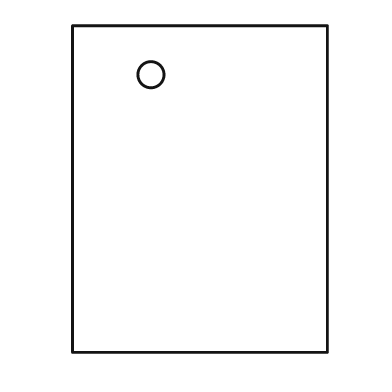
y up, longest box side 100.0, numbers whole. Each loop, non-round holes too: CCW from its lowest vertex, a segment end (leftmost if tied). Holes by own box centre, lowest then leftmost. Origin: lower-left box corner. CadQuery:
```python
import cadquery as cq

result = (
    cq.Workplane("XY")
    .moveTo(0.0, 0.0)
    .lineTo(78.0, 0.0)
    .lineTo(78.0, 100.0)
    .lineTo(0.0, 100.0)
    .close()
    .moveTo(24.0, 85.0)
    .circle(4.0)
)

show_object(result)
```